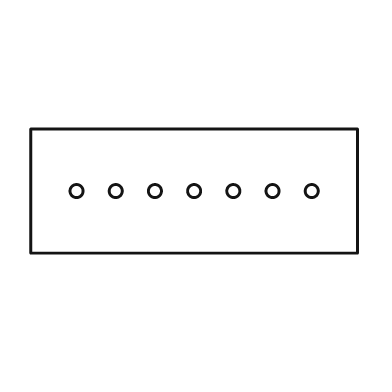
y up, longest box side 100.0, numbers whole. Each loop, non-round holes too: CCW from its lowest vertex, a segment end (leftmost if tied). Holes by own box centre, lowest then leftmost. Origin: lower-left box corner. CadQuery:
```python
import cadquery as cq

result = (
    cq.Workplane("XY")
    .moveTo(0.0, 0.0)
    .lineTo(100.0, 0.0)
    .lineTo(100.0, 38.0)
    .lineTo(0.0, 38.0)
    .close()
    .moveTo(14.0, 19.0)
    .circle(2.0)
    .moveTo(26.0, 19.0)
    .circle(2.0)
    .moveTo(38.0, 19.0)
    .circle(2.0)
    .moveTo(50.0, 19.0)
    .circle(2.0)
    .moveTo(62.0, 19.0)
    .circle(2.0)
    .moveTo(74.0, 19.0)
    .circle(2.0)
    .moveTo(86.0, 19.0)
    .circle(2.0)
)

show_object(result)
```